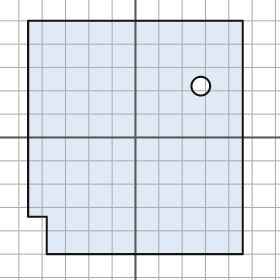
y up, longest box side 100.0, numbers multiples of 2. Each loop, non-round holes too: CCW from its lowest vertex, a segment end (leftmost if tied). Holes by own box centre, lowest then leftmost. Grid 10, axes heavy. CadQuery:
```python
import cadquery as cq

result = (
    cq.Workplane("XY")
    .moveTo(-38.0, -50.0)
    .lineTo(46.0, -50.0)
    .lineTo(46.0, 50.0)
    .lineTo(-46.0, 50.0)
    .lineTo(-46.0, -34.0)
    .lineTo(-38.0, -34.0)
    .close()
    .moveTo(28.0, 22.0)
    .circle(4.0)
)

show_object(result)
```